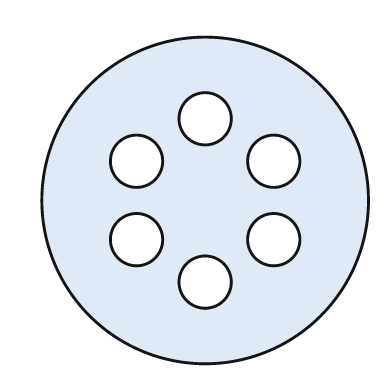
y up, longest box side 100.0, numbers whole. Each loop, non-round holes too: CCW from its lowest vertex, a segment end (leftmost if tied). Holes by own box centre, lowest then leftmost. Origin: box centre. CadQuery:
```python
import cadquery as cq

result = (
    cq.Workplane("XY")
    .moveTo(0.0, 0.0)
    .circle(50.0)
    .moveTo(0.0, -25.0)
    .circle(8.0)
    .moveTo(-21.0, -12.0)
    .circle(8.0)
    .moveTo(21.0, -12.0)
    .circle(8.0)
    .moveTo(-21.0, 12.0)
    .circle(8.0)
    .moveTo(21.0, 12.0)
    .circle(8.0)
    .moveTo(0.0, 25.0)
    .circle(8.0)
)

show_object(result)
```